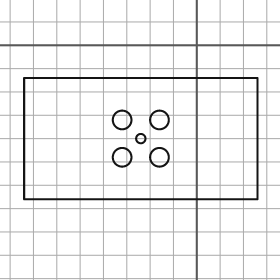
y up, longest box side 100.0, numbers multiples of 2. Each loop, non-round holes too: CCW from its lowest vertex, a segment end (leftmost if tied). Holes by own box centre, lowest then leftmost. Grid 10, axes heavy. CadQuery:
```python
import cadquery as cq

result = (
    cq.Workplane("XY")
    .moveTo(-74.0, -66.0)
    .lineTo(26.0, -66.0)
    .lineTo(26.0, -14.0)
    .lineTo(-74.0, -14.0)
    .close()
    .moveTo(-32.0, -48.0)
    .circle(4.0)
    .moveTo(-16.0, -48.0)
    .circle(4.0)
    .moveTo(-24.0, -40.0)
    .circle(2.0)
    .moveTo(-32.0, -32.0)
    .circle(4.0)
    .moveTo(-16.0, -32.0)
    .circle(4.0)
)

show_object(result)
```